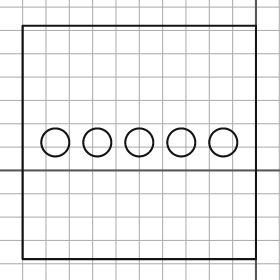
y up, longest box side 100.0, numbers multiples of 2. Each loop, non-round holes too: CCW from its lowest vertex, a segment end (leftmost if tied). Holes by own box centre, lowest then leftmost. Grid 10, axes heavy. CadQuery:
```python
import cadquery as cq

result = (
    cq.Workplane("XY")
    .moveTo(-100.0, -38.0)
    .lineTo(0.0, -38.0)
    .lineTo(0.0, 62.0)
    .lineTo(-100.0, 62.0)
    .close()
    .moveTo(-86.0, 12.0)
    .circle(6.0)
    .moveTo(-68.0, 12.0)
    .circle(6.0)
    .moveTo(-50.0, 12.0)
    .circle(6.0)
    .moveTo(-32.0, 12.0)
    .circle(6.0)
    .moveTo(-14.0, 12.0)
    .circle(6.0)
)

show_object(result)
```